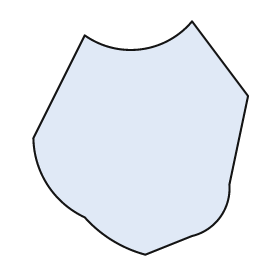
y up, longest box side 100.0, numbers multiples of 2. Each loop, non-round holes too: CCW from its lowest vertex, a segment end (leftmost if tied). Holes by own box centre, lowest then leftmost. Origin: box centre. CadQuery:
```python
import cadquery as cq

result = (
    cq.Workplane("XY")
    .moveTo(2.0, -50.0)
    .lineTo(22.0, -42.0)
    .threePointArc((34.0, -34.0), (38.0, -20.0))
    .lineTo(46.0, 18.0)
    .lineTo(22.0, 50.0)
    .threePointArc((0.0, 38.0), (-24.0, 44.0))
    .lineTo(-46.0, 0.0)
    .threePointArc((-40.0, -20.0), (-24.0, -34.0))
    .threePointArc((-12.0, -44.0), (2.0, -50.0))
    .close()
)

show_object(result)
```